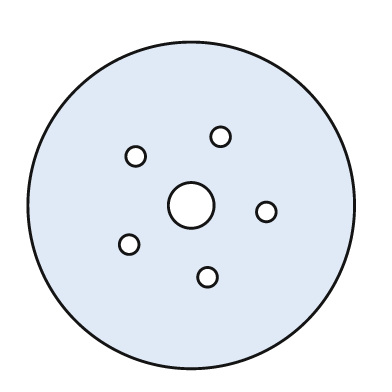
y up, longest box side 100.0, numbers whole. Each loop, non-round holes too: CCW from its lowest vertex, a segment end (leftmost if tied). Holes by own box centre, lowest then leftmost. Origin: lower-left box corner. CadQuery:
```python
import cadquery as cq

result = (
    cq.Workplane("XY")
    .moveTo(50.0, 50.0)
    .circle(50.0)
    .moveTo(55.0, 28.0)
    .circle(3.0)
    .moveTo(31.0, 38.0)
    .circle(3.0)
    .moveTo(73.0, 48.0)
    .circle(3.0)
    .moveTo(50.0, 50.0)
    .circle(7.0)
    .moveTo(33.0, 65.0)
    .circle(3.0)
    .moveTo(59.0, 71.0)
    .circle(3.0)
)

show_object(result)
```